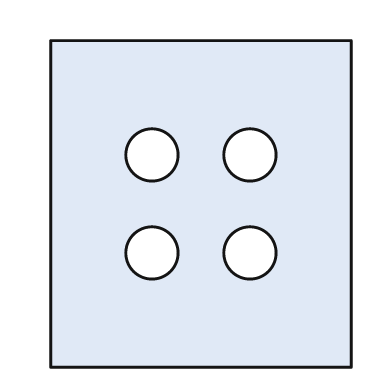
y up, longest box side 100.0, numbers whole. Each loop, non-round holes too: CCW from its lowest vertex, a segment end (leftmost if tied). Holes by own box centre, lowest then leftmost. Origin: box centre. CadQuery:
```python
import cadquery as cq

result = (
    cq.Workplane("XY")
    .moveTo(-46.0, -50.0)
    .lineTo(46.0, -50.0)
    .lineTo(46.0, 50.0)
    .lineTo(-46.0, 50.0)
    .close()
    .moveTo(-15.0, -15.0)
    .circle(8.0)
    .moveTo(15.0, -15.0)
    .circle(8.0)
    .moveTo(-15.0, 15.0)
    .circle(8.0)
    .moveTo(15.0, 15.0)
    .circle(8.0)
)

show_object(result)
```